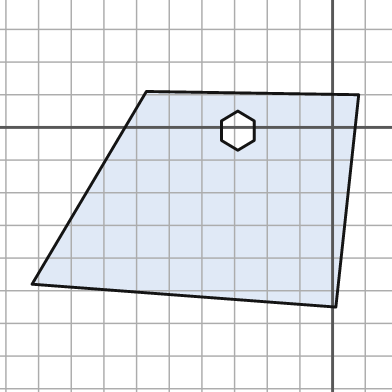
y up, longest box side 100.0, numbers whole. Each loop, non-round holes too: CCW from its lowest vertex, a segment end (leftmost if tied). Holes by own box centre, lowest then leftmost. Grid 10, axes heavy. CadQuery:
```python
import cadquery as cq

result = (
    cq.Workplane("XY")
    .moveTo(1.0, -55.0)
    .lineTo(8.0, 10.0)
    .lineTo(-57.0, 11.0)
    .lineTo(-92.0, -48.0)
    .close()
    .moveTo(-29.0, -7.0)
    .lineTo(-24.0, -4.0)
    .lineTo(-24.0, 2.0)
    .lineTo(-29.0, 5.0)
    .lineTo(-34.0, 2.0)
    .lineTo(-34.0, -4.0)
    .close()
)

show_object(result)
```